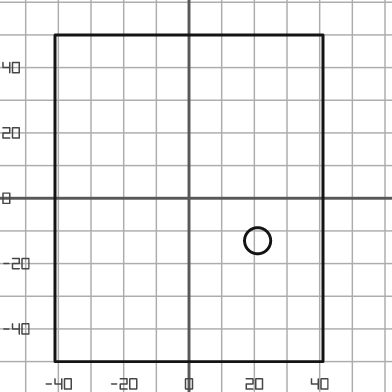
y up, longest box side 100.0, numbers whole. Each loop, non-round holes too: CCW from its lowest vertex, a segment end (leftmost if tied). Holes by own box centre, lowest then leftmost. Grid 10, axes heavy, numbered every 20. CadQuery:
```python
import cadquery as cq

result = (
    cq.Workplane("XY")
    .moveTo(-41.0, -50.0)
    .lineTo(41.0, -50.0)
    .lineTo(41.0, 50.0)
    .lineTo(-41.0, 50.0)
    .close()
    .moveTo(21.0, -13.0)
    .circle(4.0)
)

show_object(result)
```